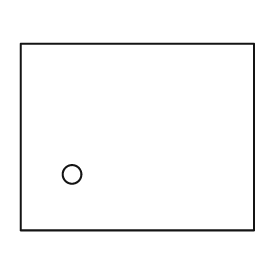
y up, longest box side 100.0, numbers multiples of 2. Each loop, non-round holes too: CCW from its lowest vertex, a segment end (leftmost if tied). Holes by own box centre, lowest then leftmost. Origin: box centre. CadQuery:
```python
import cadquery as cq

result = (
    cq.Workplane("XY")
    .moveTo(-50.0, -40.0)
    .lineTo(50.0, -40.0)
    .lineTo(50.0, 40.0)
    .lineTo(-50.0, 40.0)
    .close()
    .moveTo(-28.0, -16.0)
    .circle(4.0)
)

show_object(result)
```